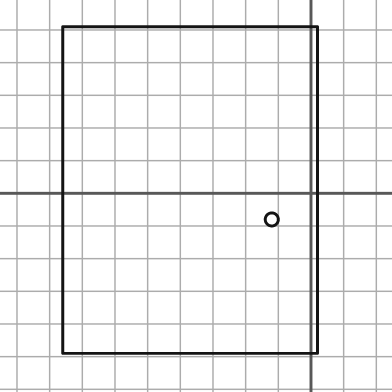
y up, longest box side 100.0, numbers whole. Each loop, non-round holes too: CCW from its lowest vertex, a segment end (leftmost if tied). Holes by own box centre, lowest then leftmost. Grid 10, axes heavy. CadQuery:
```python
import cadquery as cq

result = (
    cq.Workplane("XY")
    .moveTo(-76.0, -49.0)
    .lineTo(2.0, -49.0)
    .lineTo(2.0, 51.0)
    .lineTo(-76.0, 51.0)
    .close()
    .moveTo(-12.0, -8.0)
    .circle(2.0)
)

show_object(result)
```